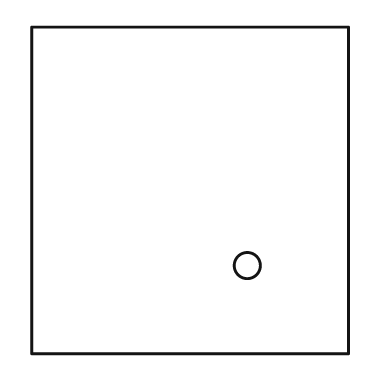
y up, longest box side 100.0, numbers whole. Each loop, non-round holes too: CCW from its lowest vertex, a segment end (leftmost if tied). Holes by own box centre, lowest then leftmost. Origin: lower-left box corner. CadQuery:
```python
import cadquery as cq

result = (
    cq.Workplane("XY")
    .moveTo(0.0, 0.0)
    .lineTo(97.0, 0.0)
    .lineTo(97.0, 100.0)
    .lineTo(0.0, 100.0)
    .close()
    .moveTo(66.0, 27.0)
    .circle(4.0)
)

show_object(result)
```